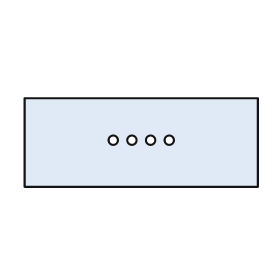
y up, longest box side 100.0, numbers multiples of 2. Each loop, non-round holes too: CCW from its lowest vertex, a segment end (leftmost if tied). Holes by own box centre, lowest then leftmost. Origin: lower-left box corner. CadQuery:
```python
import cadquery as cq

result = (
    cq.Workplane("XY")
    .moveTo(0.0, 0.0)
    .lineTo(100.0, 0.0)
    .lineTo(100.0, 38.0)
    .lineTo(0.0, 38.0)
    .close()
    .moveTo(38.0, 20.0)
    .circle(2.0)
    .moveTo(46.0, 20.0)
    .circle(2.0)
    .moveTo(54.0, 20.0)
    .circle(2.0)
    .moveTo(62.0, 20.0)
    .circle(2.0)
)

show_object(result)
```